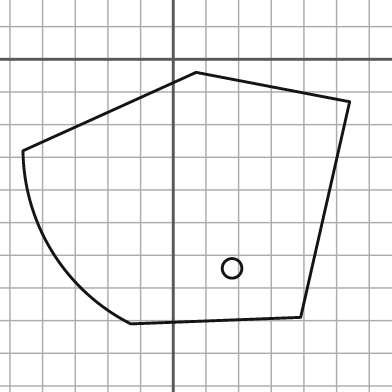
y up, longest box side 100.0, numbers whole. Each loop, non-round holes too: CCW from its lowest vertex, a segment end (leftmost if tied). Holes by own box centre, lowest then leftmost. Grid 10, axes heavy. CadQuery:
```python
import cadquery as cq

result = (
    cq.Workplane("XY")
    .moveTo(-13.0, -81.0)
    .lineTo(39.0, -79.0)
    .lineTo(54.0, -13.0)
    .lineTo(7.0, -4.0)
    .lineTo(-46.0, -28.0)
    .threePointArc((-37.0, -59.0), (-13.0, -81.0))
    .close()
    .moveTo(18.0, -64.0)
    .circle(3.0)
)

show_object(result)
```